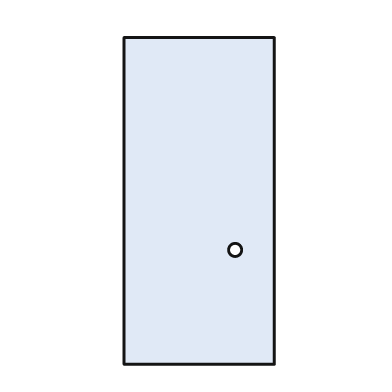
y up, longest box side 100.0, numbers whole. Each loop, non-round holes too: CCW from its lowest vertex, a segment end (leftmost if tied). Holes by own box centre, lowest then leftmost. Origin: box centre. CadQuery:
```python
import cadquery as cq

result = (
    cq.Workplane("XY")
    .moveTo(-23.0, -50.0)
    .lineTo(23.0, -50.0)
    .lineTo(23.0, 50.0)
    .lineTo(-23.0, 50.0)
    .close()
    .moveTo(11.0, -15.0)
    .circle(2.0)
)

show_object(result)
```